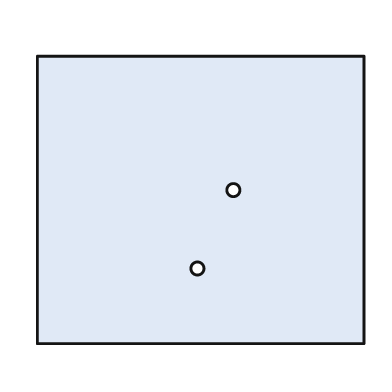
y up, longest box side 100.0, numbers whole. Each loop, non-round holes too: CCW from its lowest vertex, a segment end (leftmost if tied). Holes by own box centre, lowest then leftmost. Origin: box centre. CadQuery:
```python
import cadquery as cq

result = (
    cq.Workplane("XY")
    .moveTo(-50.0, -44.0)
    .lineTo(50.0, -44.0)
    .lineTo(50.0, 44.0)
    .lineTo(-50.0, 44.0)
    .close()
    .moveTo(-1.0, -21.0)
    .circle(2.0)
    .moveTo(10.0, 3.0)
    .circle(2.0)
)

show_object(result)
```